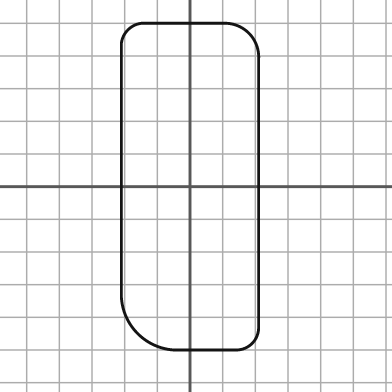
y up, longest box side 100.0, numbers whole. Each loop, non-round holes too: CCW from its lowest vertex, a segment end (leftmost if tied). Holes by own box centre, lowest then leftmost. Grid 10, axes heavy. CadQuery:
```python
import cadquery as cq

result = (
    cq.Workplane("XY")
    .moveTo(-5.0, -50.0)
    .lineTo(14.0, -50.0)
    .threePointArc((19.0, -48.0), (21.0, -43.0))
    .lineTo(21.0, 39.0)
    .threePointArc((18.0, 47.0), (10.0, 50.0))
    .lineTo(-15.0, 50.0)
    .threePointArc((-19.0, 48.0), (-21.0, 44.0))
    .lineTo(-21.0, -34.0)
    .threePointArc((-16.0, -45.0), (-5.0, -50.0))
    .close()
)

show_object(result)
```